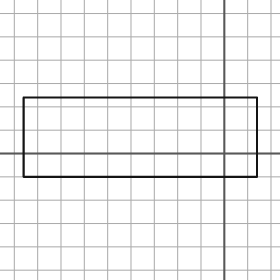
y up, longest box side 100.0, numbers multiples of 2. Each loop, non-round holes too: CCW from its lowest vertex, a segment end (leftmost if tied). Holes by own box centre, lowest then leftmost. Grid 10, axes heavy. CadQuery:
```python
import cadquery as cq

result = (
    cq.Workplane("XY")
    .moveTo(-86.0, -10.0)
    .lineTo(14.0, -10.0)
    .lineTo(14.0, 24.0)
    .lineTo(-86.0, 24.0)
    .close()
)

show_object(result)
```